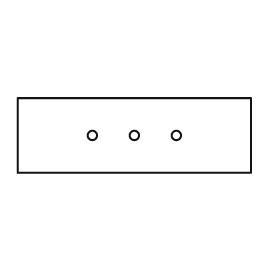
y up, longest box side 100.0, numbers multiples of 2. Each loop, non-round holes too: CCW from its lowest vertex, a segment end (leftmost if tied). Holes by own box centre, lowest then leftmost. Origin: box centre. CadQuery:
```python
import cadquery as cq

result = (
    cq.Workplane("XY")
    .moveTo(-50.0, -16.0)
    .lineTo(50.0, -16.0)
    .lineTo(50.0, 16.0)
    .lineTo(-50.0, 16.0)
    .close()
    .moveTo(-18.0, 0.0)
    .circle(2.0)
    .moveTo(0.0, 0.0)
    .circle(2.0)
    .moveTo(18.0, 0.0)
    .circle(2.0)
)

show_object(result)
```